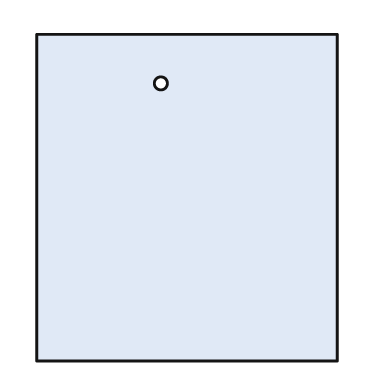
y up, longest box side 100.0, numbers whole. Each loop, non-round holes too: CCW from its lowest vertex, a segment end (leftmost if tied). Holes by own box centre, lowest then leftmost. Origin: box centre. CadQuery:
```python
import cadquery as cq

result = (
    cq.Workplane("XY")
    .moveTo(-46.0, -50.0)
    .lineTo(46.0, -50.0)
    .lineTo(46.0, 50.0)
    .lineTo(-46.0, 50.0)
    .close()
    .moveTo(-8.0, 35.0)
    .circle(2.0)
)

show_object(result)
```